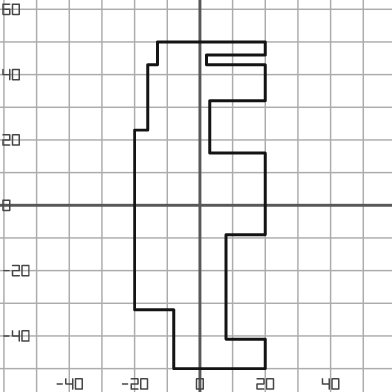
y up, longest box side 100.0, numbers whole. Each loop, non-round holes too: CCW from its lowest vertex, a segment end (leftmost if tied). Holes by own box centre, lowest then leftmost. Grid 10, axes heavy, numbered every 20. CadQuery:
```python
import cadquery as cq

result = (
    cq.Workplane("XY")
    .moveTo(-8.0, -50.0)
    .lineTo(20.0, -50.0)
    .lineTo(20.0, -41.0)
    .lineTo(8.0, -41.0)
    .lineTo(8.0, -9.0)
    .lineTo(20.0, -9.0)
    .lineTo(20.0, 16.0)
    .lineTo(3.0, 16.0)
    .lineTo(3.0, 32.0)
    .lineTo(20.0, 32.0)
    .lineTo(20.0, 43.0)
    .lineTo(2.0, 43.0)
    .lineTo(2.0, 46.0)
    .lineTo(20.0, 46.0)
    .lineTo(20.0, 50.0)
    .lineTo(-13.0, 50.0)
    .lineTo(-13.0, 43.0)
    .lineTo(-16.0, 43.0)
    .lineTo(-16.0, 23.0)
    .lineTo(-20.0, 23.0)
    .lineTo(-20.0, -32.0)
    .lineTo(-8.0, -32.0)
    .close()
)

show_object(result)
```